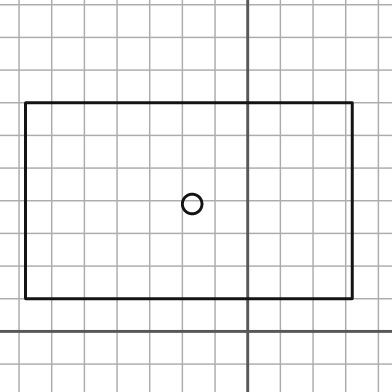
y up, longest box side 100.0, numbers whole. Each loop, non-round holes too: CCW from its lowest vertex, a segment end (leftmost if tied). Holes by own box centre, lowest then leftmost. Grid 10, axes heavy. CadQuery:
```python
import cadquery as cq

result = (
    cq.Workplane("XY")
    .moveTo(-68.0, 10.0)
    .lineTo(32.0, 10.0)
    .lineTo(32.0, 70.0)
    .lineTo(-68.0, 70.0)
    .close()
    .moveTo(-17.0, 39.0)
    .circle(3.0)
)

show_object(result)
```